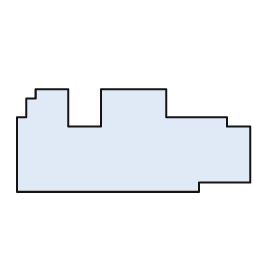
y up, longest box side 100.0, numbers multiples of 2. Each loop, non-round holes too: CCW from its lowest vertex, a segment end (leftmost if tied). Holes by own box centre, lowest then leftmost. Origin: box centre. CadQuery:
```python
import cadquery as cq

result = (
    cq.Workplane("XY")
    .moveTo(-50.0, -22.0)
    .lineTo(28.0, -22.0)
    .lineTo(28.0, -18.0)
    .lineTo(50.0, -18.0)
    .lineTo(50.0, 6.0)
    .lineTo(40.0, 6.0)
    .lineTo(40.0, 10.0)
    .lineTo(14.0, 10.0)
    .lineTo(14.0, 22.0)
    .lineTo(-14.0, 22.0)
    .lineTo(-14.0, 6.0)
    .lineTo(-28.0, 6.0)
    .lineTo(-28.0, 22.0)
    .lineTo(-42.0, 22.0)
    .lineTo(-42.0, 18.0)
    .lineTo(-46.0, 18.0)
    .lineTo(-46.0, 10.0)
    .lineTo(-50.0, 10.0)
    .close()
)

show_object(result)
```